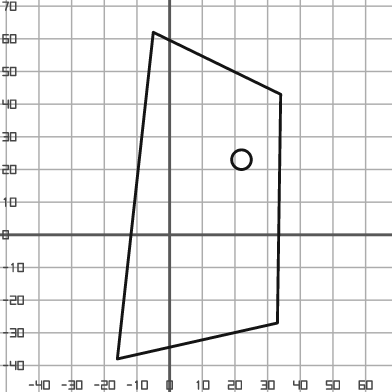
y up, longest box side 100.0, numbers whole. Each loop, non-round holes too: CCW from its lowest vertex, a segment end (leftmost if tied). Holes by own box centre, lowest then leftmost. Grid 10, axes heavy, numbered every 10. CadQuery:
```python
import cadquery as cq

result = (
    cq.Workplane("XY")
    .moveTo(-16.0, -38.0)
    .lineTo(33.0, -27.0)
    .lineTo(34.0, 43.0)
    .lineTo(-5.0, 62.0)
    .close()
    .moveTo(22.0, 23.0)
    .circle(3.0)
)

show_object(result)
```